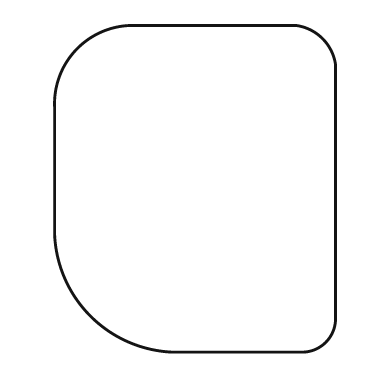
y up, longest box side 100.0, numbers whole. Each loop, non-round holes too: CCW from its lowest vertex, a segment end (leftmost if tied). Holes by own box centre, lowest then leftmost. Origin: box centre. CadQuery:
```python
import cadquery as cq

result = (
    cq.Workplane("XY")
    .moveTo(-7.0, -50.0)
    .lineTo(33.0, -50.0)
    .threePointArc((40.0, -47.0), (43.0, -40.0))
    .lineTo(43.0, 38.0)
    .threePointArc((39.0, 46.0), (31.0, 50.0))
    .lineTo(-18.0, 50.0)
    .threePointArc((-36.0, 43.0), (-43.0, 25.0))
    .lineTo(-43.0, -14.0)
    .threePointArc((-32.0, -39.0), (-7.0, -50.0))
    .close()
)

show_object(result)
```